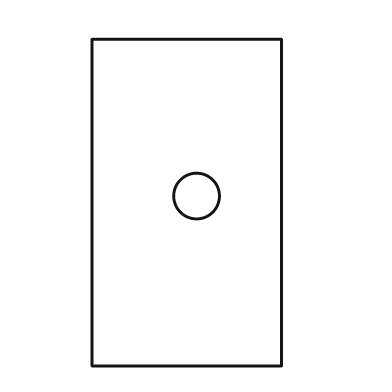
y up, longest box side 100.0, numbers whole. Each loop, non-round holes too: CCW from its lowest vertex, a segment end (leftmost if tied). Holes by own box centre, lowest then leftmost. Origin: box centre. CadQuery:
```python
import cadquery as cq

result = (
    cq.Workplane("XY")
    .moveTo(-29.0, -50.0)
    .lineTo(29.0, -50.0)
    .lineTo(29.0, 50.0)
    .lineTo(-29.0, 50.0)
    .close()
    .moveTo(3.0, 2.0)
    .circle(7.0)
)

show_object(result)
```